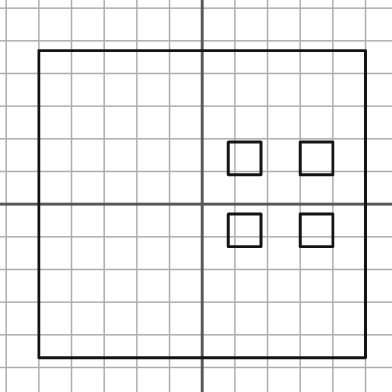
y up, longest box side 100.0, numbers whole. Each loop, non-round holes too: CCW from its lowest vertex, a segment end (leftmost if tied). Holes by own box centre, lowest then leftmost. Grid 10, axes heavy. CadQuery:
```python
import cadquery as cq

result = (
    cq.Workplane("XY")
    .moveTo(-50.0, -47.0)
    .lineTo(50.0, -47.0)
    .lineTo(50.0, 47.0)
    .lineTo(-50.0, 47.0)
    .close()
    .moveTo(8.0, -13.0)
    .lineTo(18.0, -13.0)
    .lineTo(18.0, -3.0)
    .lineTo(8.0, -3.0)
    .close()
    .moveTo(30.0, -13.0)
    .lineTo(40.0, -13.0)
    .lineTo(40.0, -3.0)
    .lineTo(30.0, -3.0)
    .close()
    .moveTo(8.0, 9.0)
    .lineTo(18.0, 9.0)
    .lineTo(18.0, 19.0)
    .lineTo(8.0, 19.0)
    .close()
    .moveTo(30.0, 9.0)
    .lineTo(40.0, 9.0)
    .lineTo(40.0, 19.0)
    .lineTo(30.0, 19.0)
    .close()
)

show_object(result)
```